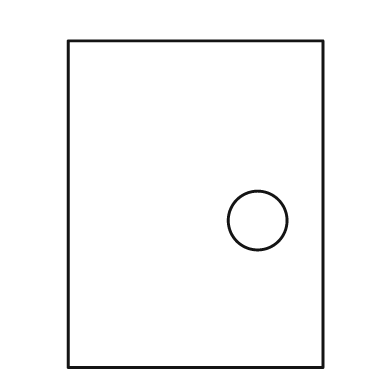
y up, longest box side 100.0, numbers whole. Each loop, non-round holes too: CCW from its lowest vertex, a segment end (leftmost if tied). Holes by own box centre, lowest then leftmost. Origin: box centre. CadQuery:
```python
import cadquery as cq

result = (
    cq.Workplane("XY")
    .moveTo(-39.0, -50.0)
    .lineTo(39.0, -50.0)
    .lineTo(39.0, 50.0)
    .lineTo(-39.0, 50.0)
    .close()
    .moveTo(19.0, -5.0)
    .circle(9.0)
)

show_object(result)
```